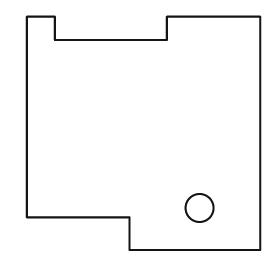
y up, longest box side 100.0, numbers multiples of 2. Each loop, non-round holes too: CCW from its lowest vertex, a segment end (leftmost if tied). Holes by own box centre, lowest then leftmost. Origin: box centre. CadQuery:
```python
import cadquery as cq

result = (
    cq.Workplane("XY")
    .moveTo(-6.0, -50.0)
    .lineTo(50.0, -50.0)
    .lineTo(50.0, 50.0)
    .lineTo(10.0, 50.0)
    .lineTo(10.0, 40.0)
    .lineTo(-38.0, 40.0)
    .lineTo(-38.0, 50.0)
    .lineTo(-50.0, 50.0)
    .lineTo(-50.0, -36.0)
    .lineTo(-6.0, -36.0)
    .close()
    .moveTo(24.0, -32.0)
    .circle(6.0)
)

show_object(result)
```